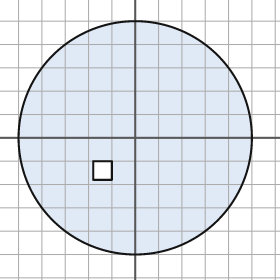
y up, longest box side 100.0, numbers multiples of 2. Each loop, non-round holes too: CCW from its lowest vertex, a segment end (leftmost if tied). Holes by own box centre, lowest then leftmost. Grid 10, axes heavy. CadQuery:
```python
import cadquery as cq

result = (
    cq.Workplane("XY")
    .moveTo(0.0, 0.0)
    .circle(50.0)
    .moveTo(-18.0, -18.0)
    .lineTo(-10.0, -18.0)
    .lineTo(-10.0, -10.0)
    .lineTo(-18.0, -10.0)
    .close()
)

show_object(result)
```